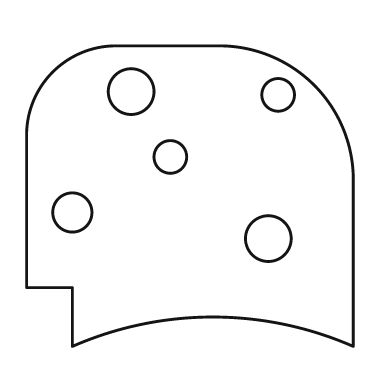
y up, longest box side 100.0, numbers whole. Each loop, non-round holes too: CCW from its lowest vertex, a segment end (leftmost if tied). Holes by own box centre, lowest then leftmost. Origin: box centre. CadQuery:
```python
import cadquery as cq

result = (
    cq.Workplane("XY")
    .moveTo(-36.0, -46.0)
    .threePointArc((7.0, -37.0), (50.0, -46.0))
    .lineTo(50.0, 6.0)
    .threePointArc((38.0, 34.0), (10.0, 46.0))
    .lineTo(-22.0, 46.0)
    .threePointArc((-42.0, 38.0), (-50.0, 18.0))
    .lineTo(-50.0, -28.0)
    .lineTo(-36.0, -28.0)
    .close()
    .moveTo(24.0, -13.0)
    .circle(7.0)
    .moveTo(-36.0, -5.0)
    .circle(6.0)
    .moveTo(-6.0, 12.0)
    .circle(5.0)
    .moveTo(27.0, 31.0)
    .circle(5.0)
    .moveTo(-18.0, 32.0)
    .circle(7.0)
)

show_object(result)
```